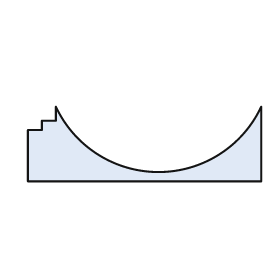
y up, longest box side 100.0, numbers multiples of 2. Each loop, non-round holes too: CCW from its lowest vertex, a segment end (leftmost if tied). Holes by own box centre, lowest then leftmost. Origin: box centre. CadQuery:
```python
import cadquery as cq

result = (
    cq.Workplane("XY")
    .moveTo(-50.0, -16.0)
    .lineTo(50.0, -16.0)
    .lineTo(50.0, 16.0)
    .threePointArc((6.0, -12.0), (-38.0, 16.0))
    .lineTo(-38.0, 10.0)
    .lineTo(-44.0, 10.0)
    .lineTo(-44.0, 6.0)
    .lineTo(-50.0, 6.0)
    .close()
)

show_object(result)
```